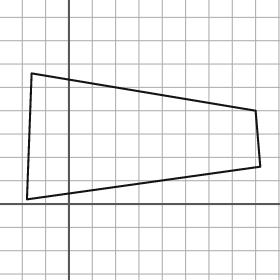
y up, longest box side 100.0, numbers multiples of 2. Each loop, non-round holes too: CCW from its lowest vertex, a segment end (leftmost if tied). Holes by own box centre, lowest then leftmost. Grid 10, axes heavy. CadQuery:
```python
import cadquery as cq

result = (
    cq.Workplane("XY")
    .moveTo(-18.0, 2.0)
    .lineTo(82.0, 16.0)
    .lineTo(80.0, 40.0)
    .lineTo(-16.0, 56.0)
    .close()
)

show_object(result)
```